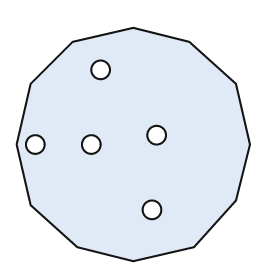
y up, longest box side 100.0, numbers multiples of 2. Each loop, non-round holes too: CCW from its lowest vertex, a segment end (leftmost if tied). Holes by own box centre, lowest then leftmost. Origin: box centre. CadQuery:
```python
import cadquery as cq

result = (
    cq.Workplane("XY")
    .moveTo(0.0, -50.0)
    .lineTo(26.0, -44.0)
    .lineTo(44.0, -24.0)
    .lineTo(50.0, 0.0)
    .lineTo(44.0, 26.0)
    .lineTo(24.0, 44.0)
    .lineTo(0.0, 50.0)
    .lineTo(-26.0, 44.0)
    .lineTo(-44.0, 26.0)
    .lineTo(-50.0, 0.0)
    .lineTo(-44.0, -26.0)
    .lineTo(-24.0, -44.0)
    .close()
    .moveTo(8.0, -28.0)
    .circle(4.0)
    .moveTo(-42.0, 0.0)
    .circle(4.0)
    .moveTo(-18.0, 0.0)
    .circle(4.0)
    .moveTo(10.0, 4.0)
    .circle(4.0)
    .moveTo(-14.0, 32.0)
    .circle(4.0)
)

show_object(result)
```